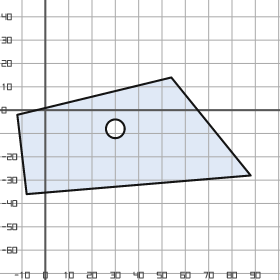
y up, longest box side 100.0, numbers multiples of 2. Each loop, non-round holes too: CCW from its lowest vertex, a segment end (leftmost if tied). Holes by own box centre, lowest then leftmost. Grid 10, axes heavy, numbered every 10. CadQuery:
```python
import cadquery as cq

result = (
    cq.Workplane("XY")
    .moveTo(-8.0, -36.0)
    .lineTo(88.0, -28.0)
    .lineTo(54.0, 14.0)
    .lineTo(-12.0, -2.0)
    .close()
    .moveTo(30.0, -8.0)
    .circle(4.0)
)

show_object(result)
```